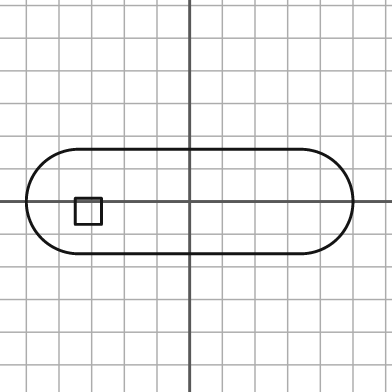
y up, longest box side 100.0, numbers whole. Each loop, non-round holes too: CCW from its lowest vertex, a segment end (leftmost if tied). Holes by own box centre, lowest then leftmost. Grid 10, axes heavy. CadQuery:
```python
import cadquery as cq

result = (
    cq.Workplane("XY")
    .moveTo(-34.0, -16.0)
    .lineTo(34.0, -16.0)
    .threePointArc((50.0, 0.0), (34.0, 16.0))
    .lineTo(-34.0, 16.0)
    .threePointArc((-50.0, 0.0), (-34.0, -16.0))
    .close()
    .moveTo(-35.0, -7.0)
    .lineTo(-27.0, -7.0)
    .lineTo(-27.0, 1.0)
    .lineTo(-35.0, 1.0)
    .close()
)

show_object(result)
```